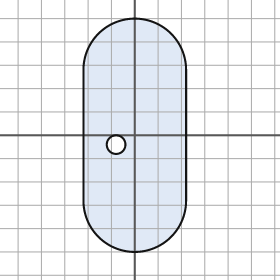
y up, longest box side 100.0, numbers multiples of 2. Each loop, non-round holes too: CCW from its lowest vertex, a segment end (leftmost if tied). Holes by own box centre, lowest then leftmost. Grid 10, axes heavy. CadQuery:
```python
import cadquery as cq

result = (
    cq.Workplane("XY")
    .moveTo(-22.0, -28.0)
    .threePointArc((0.0, -50.0), (22.0, -28.0))
    .lineTo(22.0, 28.0)
    .threePointArc((0.0, 50.0), (-22.0, 28.0))
    .close()
    .moveTo(-8.0, -4.0)
    .circle(4.0)
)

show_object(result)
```